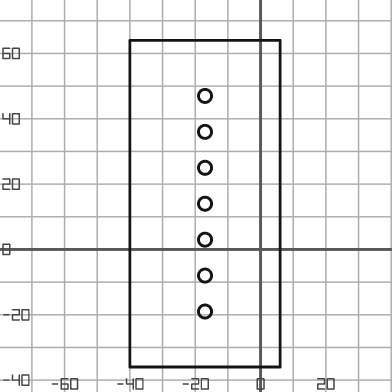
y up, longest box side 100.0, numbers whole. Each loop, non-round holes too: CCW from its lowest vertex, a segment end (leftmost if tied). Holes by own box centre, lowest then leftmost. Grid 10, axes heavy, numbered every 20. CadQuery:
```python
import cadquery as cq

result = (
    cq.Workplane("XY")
    .moveTo(-40.0, -36.0)
    .lineTo(6.0, -36.0)
    .lineTo(6.0, 64.0)
    .lineTo(-40.0, 64.0)
    .close()
    .moveTo(-17.0, -19.0)
    .circle(2.0)
    .moveTo(-17.0, -8.0)
    .circle(2.0)
    .moveTo(-17.0, 3.0)
    .circle(2.0)
    .moveTo(-17.0, 14.0)
    .circle(2.0)
    .moveTo(-17.0, 25.0)
    .circle(2.0)
    .moveTo(-17.0, 36.0)
    .circle(2.0)
    .moveTo(-17.0, 47.0)
    .circle(2.0)
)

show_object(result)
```